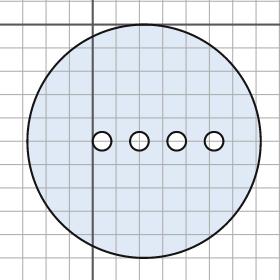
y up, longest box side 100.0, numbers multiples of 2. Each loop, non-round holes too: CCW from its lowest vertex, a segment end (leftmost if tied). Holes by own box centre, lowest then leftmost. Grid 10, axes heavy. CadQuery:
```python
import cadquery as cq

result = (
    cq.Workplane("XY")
    .moveTo(22.0, -50.0)
    .circle(50.0)
    .moveTo(4.0, -50.0)
    .circle(4.0)
    .moveTo(20.0, -50.0)
    .circle(4.0)
    .moveTo(36.0, -50.0)
    .circle(4.0)
    .moveTo(52.0, -50.0)
    .circle(4.0)
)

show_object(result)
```